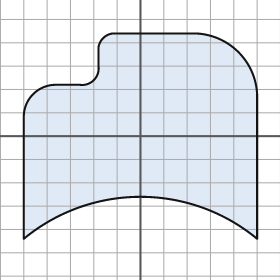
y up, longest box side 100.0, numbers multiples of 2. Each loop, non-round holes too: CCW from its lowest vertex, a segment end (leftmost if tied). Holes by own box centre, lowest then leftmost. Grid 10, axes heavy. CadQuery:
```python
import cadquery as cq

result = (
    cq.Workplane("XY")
    .moveTo(-50.0, -44.0)
    .threePointArc((0.0, -26.0), (50.0, -44.0))
    .lineTo(50.0, 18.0)
    .threePointArc((42.0, 36.0), (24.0, 44.0))
    .lineTo(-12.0, 44.0)
    .threePointArc((-16.0, 42.0), (-18.0, 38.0))
    .lineTo(-18.0, 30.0)
    .threePointArc((-20.0, 24.0), (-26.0, 22.0))
    .lineTo(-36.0, 22.0)
    .threePointArc((-46.0, 18.0), (-50.0, 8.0))
    .close()
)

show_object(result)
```